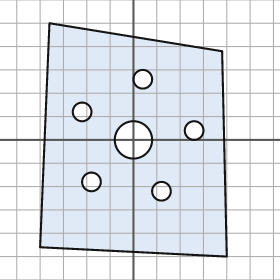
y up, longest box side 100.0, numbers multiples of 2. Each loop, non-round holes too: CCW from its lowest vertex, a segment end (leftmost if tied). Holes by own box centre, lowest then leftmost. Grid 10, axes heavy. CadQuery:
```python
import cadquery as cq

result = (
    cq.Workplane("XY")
    .moveTo(40.0, -50.0)
    .lineTo(38.0, 38.0)
    .lineTo(-36.0, 50.0)
    .lineTo(-40.0, -46.0)
    .close()
    .moveTo(12.0, -22.0)
    .circle(4.0)
    .moveTo(-18.0, -18.0)
    .circle(4.0)
    .moveTo(0.0, 0.0)
    .circle(8.0)
    .moveTo(26.0, 4.0)
    .circle(4.0)
    .moveTo(-22.0, 12.0)
    .circle(4.0)
    .moveTo(4.0, 26.0)
    .circle(4.0)
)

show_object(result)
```